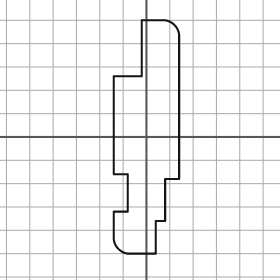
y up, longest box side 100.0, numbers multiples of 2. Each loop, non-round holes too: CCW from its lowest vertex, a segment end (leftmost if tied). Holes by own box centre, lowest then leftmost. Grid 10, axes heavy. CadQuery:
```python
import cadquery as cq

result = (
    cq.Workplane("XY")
    .moveTo(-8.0, -50.0)
    .lineTo(4.0, -50.0)
    .lineTo(4.0, -36.0)
    .lineTo(8.0, -36.0)
    .lineTo(8.0, -18.0)
    .lineTo(14.0, -18.0)
    .lineTo(14.0, 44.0)
    .threePointArc((12.0, 48.0), (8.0, 50.0))
    .lineTo(-2.0, 50.0)
    .lineTo(-2.0, 26.0)
    .lineTo(-14.0, 26.0)
    .lineTo(-14.0, -16.0)
    .lineTo(-8.0, -16.0)
    .lineTo(-8.0, -32.0)
    .lineTo(-14.0, -32.0)
    .lineTo(-14.0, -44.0)
    .threePointArc((-12.0, -48.0), (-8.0, -50.0))
    .close()
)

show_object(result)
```